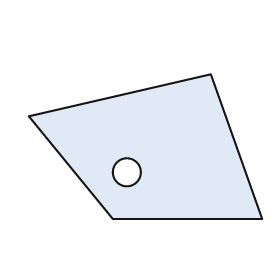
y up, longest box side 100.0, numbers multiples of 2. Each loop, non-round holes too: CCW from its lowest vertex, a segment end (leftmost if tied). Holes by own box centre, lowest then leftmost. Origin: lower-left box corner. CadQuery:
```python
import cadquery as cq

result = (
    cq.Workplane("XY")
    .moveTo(36.0, 0.0)
    .lineTo(100.0, 0.0)
    .lineTo(78.0, 62.0)
    .lineTo(0.0, 44.0)
    .close()
    .moveTo(42.0, 20.0)
    .circle(6.0)
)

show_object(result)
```